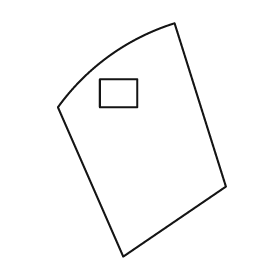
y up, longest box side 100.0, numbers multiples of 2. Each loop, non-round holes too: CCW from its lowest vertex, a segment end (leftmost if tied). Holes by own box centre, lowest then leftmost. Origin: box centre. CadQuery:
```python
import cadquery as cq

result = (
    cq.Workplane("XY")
    .moveTo(-8.0, -50.0)
    .lineTo(36.0, -20.0)
    .lineTo(14.0, 50.0)
    .threePointArc((-14.0, 36.0), (-36.0, 14.0))
    .close()
    .moveTo(-18.0, 14.0)
    .lineTo(-2.0, 14.0)
    .lineTo(-2.0, 26.0)
    .lineTo(-18.0, 26.0)
    .close()
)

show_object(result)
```